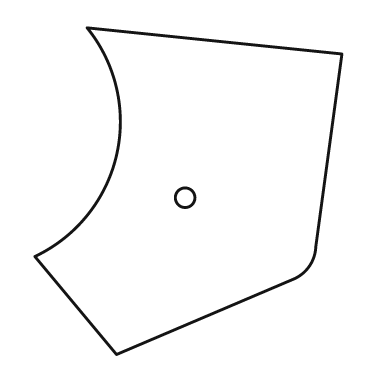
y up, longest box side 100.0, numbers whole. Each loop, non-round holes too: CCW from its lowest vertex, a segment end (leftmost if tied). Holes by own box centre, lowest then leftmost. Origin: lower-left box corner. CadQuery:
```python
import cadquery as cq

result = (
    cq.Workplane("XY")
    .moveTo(25.0, 0.0)
    .lineTo(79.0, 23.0)
    .threePointArc((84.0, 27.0), (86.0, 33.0))
    .lineTo(94.0, 92.0)
    .lineTo(16.0, 100.0)
    .threePointArc((25.0, 61.0), (0.0, 30.0))
    .close()
    .moveTo(46.0, 48.0)
    .circle(3.0)
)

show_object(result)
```